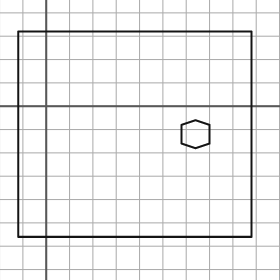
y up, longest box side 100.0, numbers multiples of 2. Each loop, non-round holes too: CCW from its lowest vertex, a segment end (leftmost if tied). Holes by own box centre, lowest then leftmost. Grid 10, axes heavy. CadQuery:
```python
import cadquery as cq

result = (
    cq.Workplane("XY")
    .moveTo(-12.0, -56.0)
    .lineTo(88.0, -56.0)
    .lineTo(88.0, 32.0)
    .lineTo(-12.0, 32.0)
    .close()
    .moveTo(64.0, -18.0)
    .lineTo(70.0, -16.0)
    .lineTo(70.0, -8.0)
    .lineTo(64.0, -6.0)
    .lineTo(58.0, -8.0)
    .lineTo(58.0, -16.0)
    .close()
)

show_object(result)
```